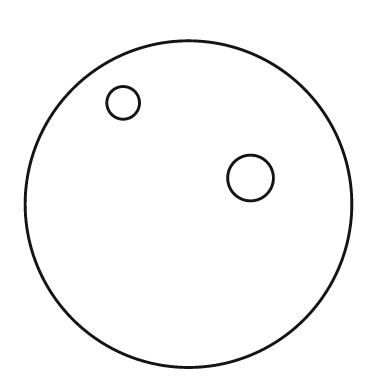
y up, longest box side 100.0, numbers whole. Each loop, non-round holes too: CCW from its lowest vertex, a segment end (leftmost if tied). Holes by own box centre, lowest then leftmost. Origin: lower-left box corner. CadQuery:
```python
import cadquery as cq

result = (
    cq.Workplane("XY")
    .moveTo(50.0, 50.0)
    .circle(50.0)
    .moveTo(69.0, 58.0)
    .circle(7.0)
    .moveTo(30.0, 81.0)
    .circle(5.0)
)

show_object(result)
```